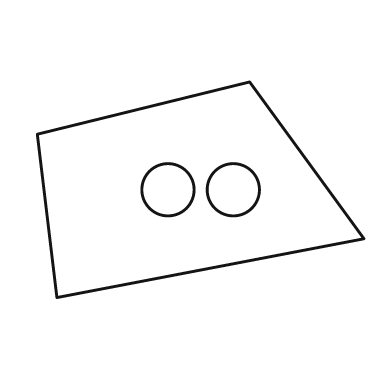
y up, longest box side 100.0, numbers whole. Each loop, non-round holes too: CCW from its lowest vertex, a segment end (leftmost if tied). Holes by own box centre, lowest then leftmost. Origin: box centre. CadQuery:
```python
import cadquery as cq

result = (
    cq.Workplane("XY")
    .moveTo(-44.0, -33.0)
    .lineTo(50.0, -15.0)
    .lineTo(15.0, 33.0)
    .lineTo(-50.0, 17.0)
    .close()
    .moveTo(-10.0, 0.0)
    .circle(8.0)
    .moveTo(10.0, 0.0)
    .circle(8.0)
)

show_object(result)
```